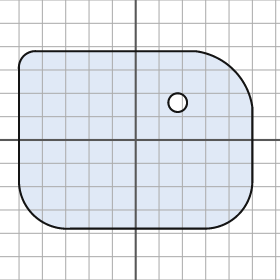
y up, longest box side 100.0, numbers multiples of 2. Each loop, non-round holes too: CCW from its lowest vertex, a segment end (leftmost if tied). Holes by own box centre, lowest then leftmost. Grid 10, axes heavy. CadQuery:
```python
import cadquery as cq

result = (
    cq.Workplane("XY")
    .moveTo(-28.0, -38.0)
    .lineTo(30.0, -38.0)
    .threePointArc((44.0, -32.0), (50.0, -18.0))
    .lineTo(50.0, 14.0)
    .threePointArc((42.0, 30.0), (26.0, 38.0))
    .lineTo(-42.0, 38.0)
    .threePointArc((-48.0, 36.0), (-50.0, 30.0))
    .lineTo(-50.0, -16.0)
    .threePointArc((-44.0, -32.0), (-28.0, -38.0))
    .close()
    .moveTo(18.0, 16.0)
    .circle(4.0)
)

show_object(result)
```